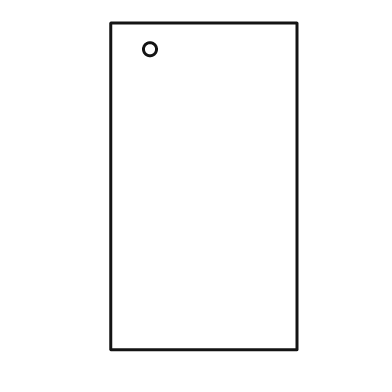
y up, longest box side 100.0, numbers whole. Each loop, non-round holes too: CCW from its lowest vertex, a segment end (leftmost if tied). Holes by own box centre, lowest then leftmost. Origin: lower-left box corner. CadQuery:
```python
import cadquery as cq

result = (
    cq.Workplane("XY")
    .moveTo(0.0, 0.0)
    .lineTo(57.0, 0.0)
    .lineTo(57.0, 100.0)
    .lineTo(0.0, 100.0)
    .close()
    .moveTo(12.0, 92.0)
    .circle(2.0)
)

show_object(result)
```